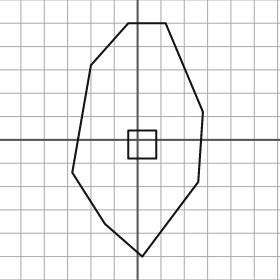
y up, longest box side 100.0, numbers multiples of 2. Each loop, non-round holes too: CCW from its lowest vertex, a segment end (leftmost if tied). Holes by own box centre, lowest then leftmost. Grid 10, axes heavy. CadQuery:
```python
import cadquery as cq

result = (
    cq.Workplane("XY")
    .moveTo(2.0, -50.0)
    .lineTo(26.0, -18.0)
    .lineTo(28.0, 12.0)
    .lineTo(12.0, 50.0)
    .lineTo(-4.0, 50.0)
    .lineTo(-20.0, 32.0)
    .lineTo(-28.0, -14.0)
    .lineTo(-14.0, -36.0)
    .close()
    .moveTo(-4.0, -8.0)
    .lineTo(8.0, -8.0)
    .lineTo(8.0, 4.0)
    .lineTo(-4.0, 4.0)
    .close()
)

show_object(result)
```